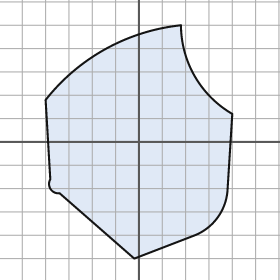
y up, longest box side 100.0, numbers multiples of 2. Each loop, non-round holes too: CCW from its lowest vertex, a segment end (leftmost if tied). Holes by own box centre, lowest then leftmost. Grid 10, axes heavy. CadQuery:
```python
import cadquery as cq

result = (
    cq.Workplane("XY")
    .moveTo(-2.0, -50.0)
    .lineTo(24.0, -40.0)
    .threePointArc((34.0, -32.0), (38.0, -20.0))
    .lineTo(40.0, 12.0)
    .threePointArc((24.0, 28.0), (18.0, 50.0))
    .threePointArc((-14.0, 40.0), (-40.0, 18.0))
    .lineTo(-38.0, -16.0)
    .threePointArc((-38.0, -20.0), (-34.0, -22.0))
    .close()
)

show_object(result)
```